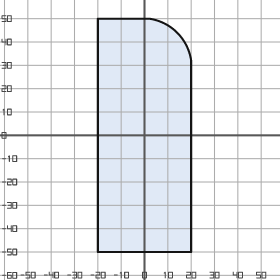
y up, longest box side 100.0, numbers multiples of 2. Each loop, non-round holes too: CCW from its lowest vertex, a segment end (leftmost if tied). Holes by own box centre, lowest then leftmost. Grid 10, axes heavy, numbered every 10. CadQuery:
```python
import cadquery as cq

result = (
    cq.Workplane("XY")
    .moveTo(-20.0, -50.0)
    .lineTo(20.0, -50.0)
    .lineTo(20.0, 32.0)
    .threePointArc((14.0, 44.0), (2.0, 50.0))
    .lineTo(-20.0, 50.0)
    .close()
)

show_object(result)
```